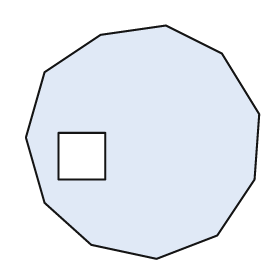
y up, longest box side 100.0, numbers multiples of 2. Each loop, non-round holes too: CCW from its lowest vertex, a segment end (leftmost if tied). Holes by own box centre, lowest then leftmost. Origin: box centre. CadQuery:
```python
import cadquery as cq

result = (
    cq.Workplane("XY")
    .moveTo(6.0, -50.0)
    .lineTo(32.0, -40.0)
    .lineTo(48.0, -16.0)
    .lineTo(50.0, 12.0)
    .lineTo(34.0, 38.0)
    .lineTo(10.0, 50.0)
    .lineTo(-18.0, 46.0)
    .lineTo(-42.0, 30.0)
    .lineTo(-50.0, 2.0)
    .lineTo(-42.0, -26.0)
    .lineTo(-22.0, -44.0)
    .close()
    .moveTo(-36.0, -16.0)
    .lineTo(-16.0, -16.0)
    .lineTo(-16.0, 4.0)
    .lineTo(-36.0, 4.0)
    .close()
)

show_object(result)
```